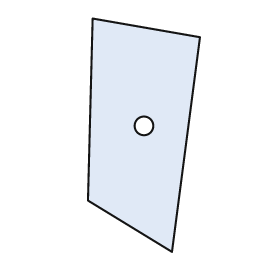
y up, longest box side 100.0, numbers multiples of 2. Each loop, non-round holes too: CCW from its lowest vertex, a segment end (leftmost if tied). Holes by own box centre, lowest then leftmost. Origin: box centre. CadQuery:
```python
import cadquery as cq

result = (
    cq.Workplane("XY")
    .moveTo(12.0, -50.0)
    .lineTo(24.0, 42.0)
    .lineTo(-22.0, 50.0)
    .lineTo(-24.0, -28.0)
    .close()
    .moveTo(0.0, 4.0)
    .circle(4.0)
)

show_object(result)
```